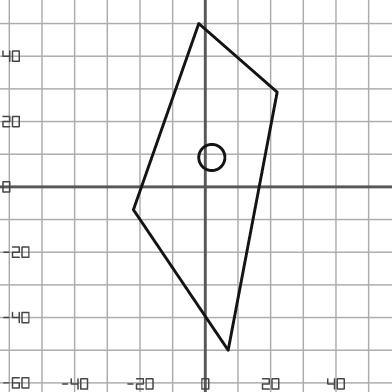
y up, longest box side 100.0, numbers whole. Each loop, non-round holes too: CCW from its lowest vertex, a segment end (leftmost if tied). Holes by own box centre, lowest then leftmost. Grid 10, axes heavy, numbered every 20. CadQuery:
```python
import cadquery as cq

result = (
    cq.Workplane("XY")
    .moveTo(7.0, -50.0)
    .lineTo(22.0, 29.0)
    .lineTo(-2.0, 50.0)
    .lineTo(-22.0, -7.0)
    .close()
    .moveTo(2.0, 9.0)
    .circle(4.0)
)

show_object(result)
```